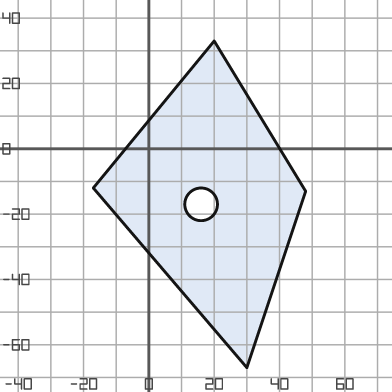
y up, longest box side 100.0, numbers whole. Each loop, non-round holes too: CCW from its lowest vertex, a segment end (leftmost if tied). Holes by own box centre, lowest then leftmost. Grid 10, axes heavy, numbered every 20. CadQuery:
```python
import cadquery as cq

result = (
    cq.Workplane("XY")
    .moveTo(30.0, -67.0)
    .lineTo(48.0, -13.0)
    .lineTo(20.0, 33.0)
    .lineTo(-17.0, -12.0)
    .close()
    .moveTo(16.0, -17.0)
    .circle(5.0)
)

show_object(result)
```